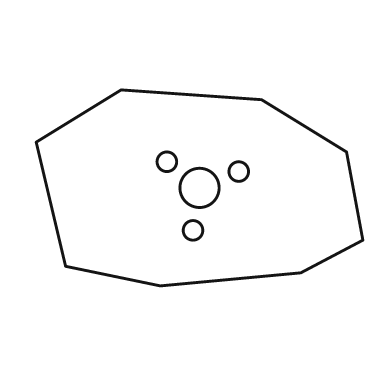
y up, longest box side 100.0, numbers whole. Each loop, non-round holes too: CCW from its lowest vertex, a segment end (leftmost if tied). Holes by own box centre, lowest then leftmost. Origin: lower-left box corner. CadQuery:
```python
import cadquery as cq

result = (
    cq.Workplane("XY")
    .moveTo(38.0, 0.0)
    .lineTo(81.0, 4.0)
    .lineTo(100.0, 14.0)
    .lineTo(95.0, 41.0)
    .lineTo(69.0, 57.0)
    .lineTo(26.0, 60.0)
    .lineTo(0.0, 44.0)
    .lineTo(9.0, 6.0)
    .close()
    .moveTo(48.0, 17.0)
    .circle(3.0)
    .moveTo(50.0, 30.0)
    .circle(6.0)
    .moveTo(62.0, 35.0)
    .circle(3.0)
    .moveTo(40.0, 38.0)
    .circle(3.0)
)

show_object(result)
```